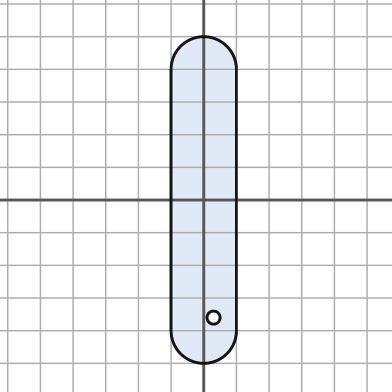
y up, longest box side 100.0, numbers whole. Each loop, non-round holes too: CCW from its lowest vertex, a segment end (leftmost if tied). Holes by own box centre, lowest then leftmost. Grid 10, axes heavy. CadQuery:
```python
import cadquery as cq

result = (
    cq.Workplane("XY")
    .moveTo(-10.0, -40.0)
    .threePointArc((0.0, -50.0), (10.0, -40.0))
    .lineTo(10.0, 40.0)
    .threePointArc((0.0, 50.0), (-10.0, 40.0))
    .close()
    .moveTo(3.0, -36.0)
    .circle(2.0)
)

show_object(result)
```